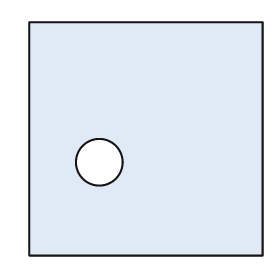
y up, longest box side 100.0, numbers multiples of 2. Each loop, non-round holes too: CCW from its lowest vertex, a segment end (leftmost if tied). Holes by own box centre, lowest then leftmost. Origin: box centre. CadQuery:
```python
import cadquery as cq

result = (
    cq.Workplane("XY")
    .moveTo(-50.0, -50.0)
    .lineTo(50.0, -50.0)
    .lineTo(50.0, 50.0)
    .lineTo(-50.0, 50.0)
    .close()
    .moveTo(-20.0, -10.0)
    .circle(10.0)
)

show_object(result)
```